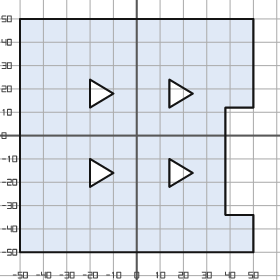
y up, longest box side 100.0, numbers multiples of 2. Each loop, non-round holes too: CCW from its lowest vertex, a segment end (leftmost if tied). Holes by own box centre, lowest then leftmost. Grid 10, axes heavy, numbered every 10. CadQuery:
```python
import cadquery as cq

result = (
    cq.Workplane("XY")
    .moveTo(-50.0, -50.0)
    .lineTo(50.0, -50.0)
    .lineTo(50.0, -34.0)
    .lineTo(38.0, -34.0)
    .lineTo(38.0, 12.0)
    .lineTo(50.0, 12.0)
    .lineTo(50.0, 50.0)
    .lineTo(-50.0, 50.0)
    .close()
    .moveTo(-20.0, -22.0)
    .lineTo(-10.0, -16.0)
    .lineTo(-20.0, -10.0)
    .close()
    .moveTo(14.0, -22.0)
    .lineTo(24.0, -16.0)
    .lineTo(14.0, -10.0)
    .close()
    .moveTo(-20.0, 12.0)
    .lineTo(-10.0, 18.0)
    .lineTo(-20.0, 24.0)
    .close()
    .moveTo(14.0, 12.0)
    .lineTo(24.0, 18.0)
    .lineTo(14.0, 24.0)
    .close()
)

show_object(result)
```